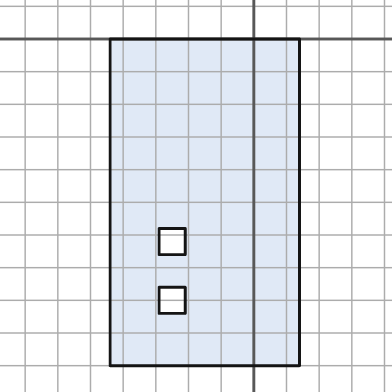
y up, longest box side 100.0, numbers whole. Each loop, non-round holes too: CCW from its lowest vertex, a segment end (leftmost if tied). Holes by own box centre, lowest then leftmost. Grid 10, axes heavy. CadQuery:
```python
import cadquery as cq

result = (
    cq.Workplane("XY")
    .moveTo(-44.0, -100.0)
    .lineTo(14.0, -100.0)
    .lineTo(14.0, 0.0)
    .lineTo(-44.0, 0.0)
    .close()
    .moveTo(-29.0, -84.0)
    .lineTo(-21.0, -84.0)
    .lineTo(-21.0, -76.0)
    .lineTo(-29.0, -76.0)
    .close()
    .moveTo(-29.0, -66.0)
    .lineTo(-21.0, -66.0)
    .lineTo(-21.0, -58.0)
    .lineTo(-29.0, -58.0)
    .close()
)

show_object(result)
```